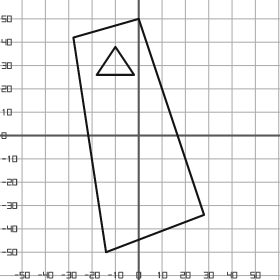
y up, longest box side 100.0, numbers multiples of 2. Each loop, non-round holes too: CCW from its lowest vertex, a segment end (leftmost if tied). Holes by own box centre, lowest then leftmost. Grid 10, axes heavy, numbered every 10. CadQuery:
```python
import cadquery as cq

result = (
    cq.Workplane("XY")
    .moveTo(-14.0, -50.0)
    .lineTo(28.0, -34.0)
    .lineTo(0.0, 50.0)
    .lineTo(-28.0, 42.0)
    .close()
    .moveTo(-18.0, 26.0)
    .lineTo(-2.0, 26.0)
    .lineTo(-10.0, 38.0)
    .close()
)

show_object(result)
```